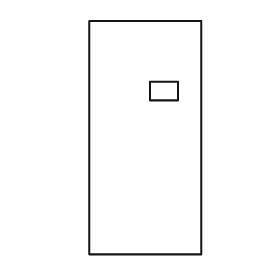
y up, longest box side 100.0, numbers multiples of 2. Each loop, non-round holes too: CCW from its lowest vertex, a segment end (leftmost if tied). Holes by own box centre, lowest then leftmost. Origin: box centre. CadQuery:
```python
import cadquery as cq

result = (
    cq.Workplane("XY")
    .moveTo(-24.0, -50.0)
    .lineTo(24.0, -50.0)
    .lineTo(24.0, 50.0)
    .lineTo(-24.0, 50.0)
    .close()
    .moveTo(2.0, 16.0)
    .lineTo(14.0, 16.0)
    .lineTo(14.0, 24.0)
    .lineTo(2.0, 24.0)
    .close()
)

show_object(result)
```